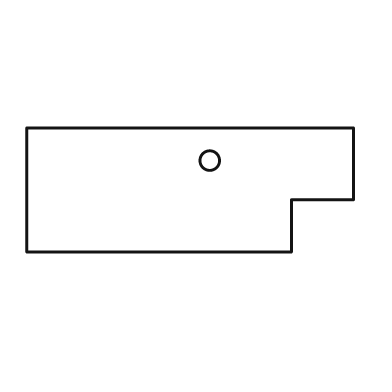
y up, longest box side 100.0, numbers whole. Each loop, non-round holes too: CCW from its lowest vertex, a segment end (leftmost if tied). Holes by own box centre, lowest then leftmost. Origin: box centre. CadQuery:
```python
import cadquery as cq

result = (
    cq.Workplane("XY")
    .moveTo(-50.0, -19.0)
    .lineTo(31.0, -19.0)
    .lineTo(31.0, -3.0)
    .lineTo(50.0, -3.0)
    .lineTo(50.0, 19.0)
    .lineTo(-50.0, 19.0)
    .close()
    .moveTo(6.0, 9.0)
    .circle(3.0)
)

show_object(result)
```